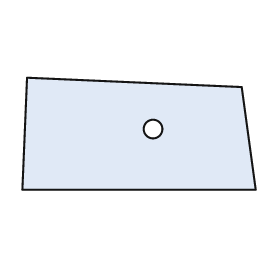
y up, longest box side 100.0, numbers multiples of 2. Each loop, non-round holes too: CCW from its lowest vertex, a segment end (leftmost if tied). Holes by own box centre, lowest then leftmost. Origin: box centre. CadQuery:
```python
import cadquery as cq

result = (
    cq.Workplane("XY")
    .moveTo(-50.0, -24.0)
    .lineTo(50.0, -24.0)
    .lineTo(44.0, 20.0)
    .lineTo(-48.0, 24.0)
    .close()
    .moveTo(6.0, 2.0)
    .circle(4.0)
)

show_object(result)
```